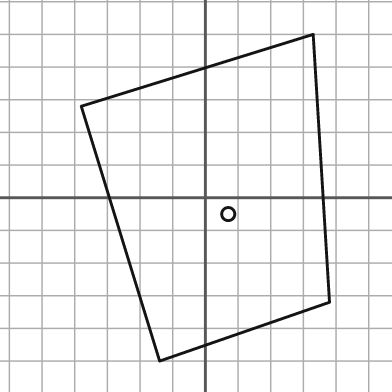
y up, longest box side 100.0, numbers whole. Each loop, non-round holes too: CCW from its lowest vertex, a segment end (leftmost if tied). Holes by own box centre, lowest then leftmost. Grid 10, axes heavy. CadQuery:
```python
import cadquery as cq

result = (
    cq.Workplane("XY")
    .moveTo(-14.0, -50.0)
    .lineTo(38.0, -32.0)
    .lineTo(33.0, 50.0)
    .lineTo(-38.0, 28.0)
    .close()
    .moveTo(7.0, -5.0)
    .circle(2.0)
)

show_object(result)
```